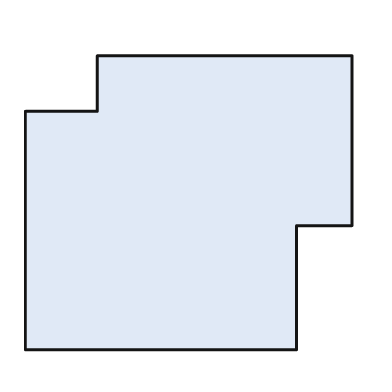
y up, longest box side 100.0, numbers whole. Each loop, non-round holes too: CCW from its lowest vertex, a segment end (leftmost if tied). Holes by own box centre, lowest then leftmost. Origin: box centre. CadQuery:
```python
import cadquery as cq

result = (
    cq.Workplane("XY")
    .moveTo(-50.0, -45.0)
    .lineTo(33.0, -45.0)
    .lineTo(33.0, -7.0)
    .lineTo(50.0, -7.0)
    .lineTo(50.0, 45.0)
    .lineTo(-28.0, 45.0)
    .lineTo(-28.0, 28.0)
    .lineTo(-50.0, 28.0)
    .close()
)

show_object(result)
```